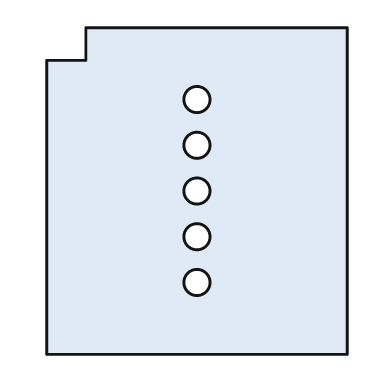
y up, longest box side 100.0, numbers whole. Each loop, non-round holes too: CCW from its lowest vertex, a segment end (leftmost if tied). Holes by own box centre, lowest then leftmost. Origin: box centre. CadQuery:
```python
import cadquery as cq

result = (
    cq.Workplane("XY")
    .moveTo(-46.0, -50.0)
    .lineTo(46.0, -50.0)
    .lineTo(46.0, 50.0)
    .lineTo(-34.0, 50.0)
    .lineTo(-34.0, 40.0)
    .lineTo(-46.0, 40.0)
    .close()
    .moveTo(0.0, -28.0)
    .circle(4.0)
    .moveTo(0.0, -14.0)
    .circle(4.0)
    .moveTo(0.0, 0.0)
    .circle(4.0)
    .moveTo(0.0, 14.0)
    .circle(4.0)
    .moveTo(0.0, 28.0)
    .circle(4.0)
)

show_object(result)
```